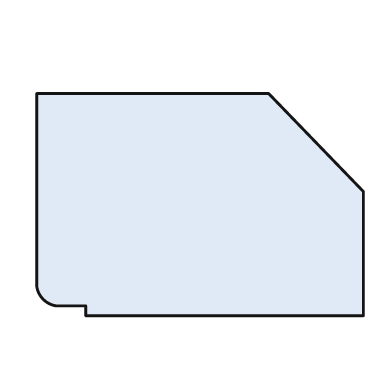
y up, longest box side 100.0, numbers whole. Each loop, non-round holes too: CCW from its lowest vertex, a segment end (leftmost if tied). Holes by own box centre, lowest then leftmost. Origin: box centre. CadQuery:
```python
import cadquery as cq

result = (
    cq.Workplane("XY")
    .moveTo(-35.0, -34.0)
    .lineTo(50.0, -34.0)
    .lineTo(50.0, 4.0)
    .lineTo(21.0, 34.0)
    .lineTo(-50.0, 34.0)
    .lineTo(-50.0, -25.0)
    .threePointArc((-48.0, -29.0), (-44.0, -31.0))
    .lineTo(-35.0, -31.0)
    .close()
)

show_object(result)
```